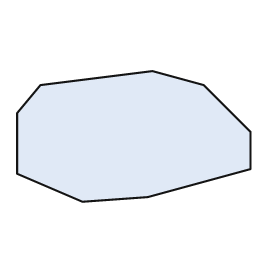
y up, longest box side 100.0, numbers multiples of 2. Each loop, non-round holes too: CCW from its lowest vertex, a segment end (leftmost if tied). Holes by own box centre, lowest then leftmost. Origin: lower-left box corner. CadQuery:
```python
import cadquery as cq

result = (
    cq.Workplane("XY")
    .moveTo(28.0, 0.0)
    .lineTo(56.0, 2.0)
    .lineTo(100.0, 14.0)
    .lineTo(100.0, 30.0)
    .lineTo(80.0, 50.0)
    .lineTo(58.0, 56.0)
    .lineTo(10.0, 50.0)
    .lineTo(0.0, 38.0)
    .lineTo(0.0, 12.0)
    .close()
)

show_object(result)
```